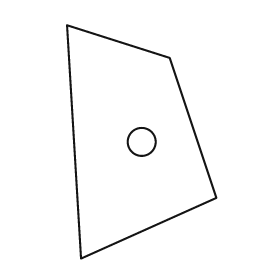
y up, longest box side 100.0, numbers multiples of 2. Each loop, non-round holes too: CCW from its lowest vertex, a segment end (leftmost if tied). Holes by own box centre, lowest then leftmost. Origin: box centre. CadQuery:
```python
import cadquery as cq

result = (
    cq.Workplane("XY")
    .moveTo(-26.0, -50.0)
    .lineTo(32.0, -24.0)
    .lineTo(12.0, 36.0)
    .lineTo(-32.0, 50.0)
    .close()
    .moveTo(0.0, 0.0)
    .circle(6.0)
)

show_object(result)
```